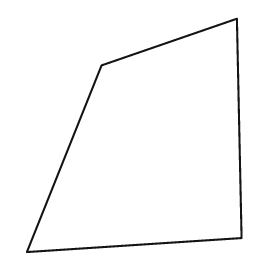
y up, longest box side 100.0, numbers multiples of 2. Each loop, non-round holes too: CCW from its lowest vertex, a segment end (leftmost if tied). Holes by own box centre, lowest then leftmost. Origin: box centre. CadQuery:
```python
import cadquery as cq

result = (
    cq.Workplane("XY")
    .moveTo(-46.0, -50.0)
    .lineTo(46.0, -44.0)
    .lineTo(44.0, 50.0)
    .lineTo(-14.0, 30.0)
    .close()
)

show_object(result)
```